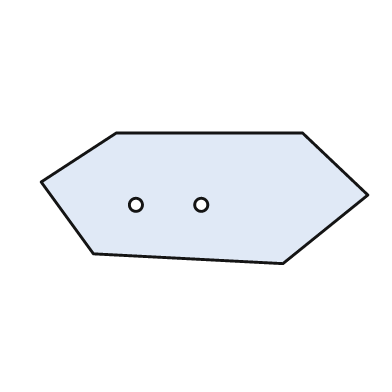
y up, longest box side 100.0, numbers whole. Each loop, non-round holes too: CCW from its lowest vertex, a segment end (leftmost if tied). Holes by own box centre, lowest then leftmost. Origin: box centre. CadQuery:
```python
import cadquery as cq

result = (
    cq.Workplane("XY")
    .moveTo(24.0, -20.0)
    .lineTo(50.0, 1.0)
    .lineTo(30.0, 20.0)
    .lineTo(-27.0, 20.0)
    .lineTo(-50.0, 5.0)
    .lineTo(-34.0, -17.0)
    .close()
    .moveTo(-21.0, -2.0)
    .circle(2.0)
    .moveTo(-1.0, -2.0)
    .circle(2.0)
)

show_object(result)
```